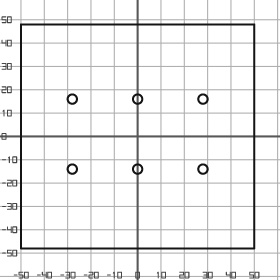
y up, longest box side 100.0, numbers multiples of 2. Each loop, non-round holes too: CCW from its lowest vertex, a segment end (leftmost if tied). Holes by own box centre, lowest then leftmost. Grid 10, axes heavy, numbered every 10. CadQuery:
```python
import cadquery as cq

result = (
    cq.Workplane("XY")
    .moveTo(-50.0, -48.0)
    .lineTo(50.0, -48.0)
    .lineTo(50.0, 48.0)
    .lineTo(-50.0, 48.0)
    .close()
    .moveTo(-28.0, -14.0)
    .circle(2.0)
    .moveTo(0.0, -14.0)
    .circle(2.0)
    .moveTo(28.0, -14.0)
    .circle(2.0)
    .moveTo(-28.0, 16.0)
    .circle(2.0)
    .moveTo(0.0, 16.0)
    .circle(2.0)
    .moveTo(28.0, 16.0)
    .circle(2.0)
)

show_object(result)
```